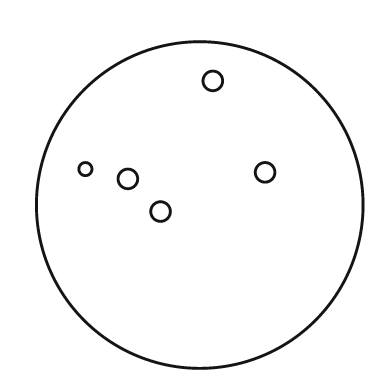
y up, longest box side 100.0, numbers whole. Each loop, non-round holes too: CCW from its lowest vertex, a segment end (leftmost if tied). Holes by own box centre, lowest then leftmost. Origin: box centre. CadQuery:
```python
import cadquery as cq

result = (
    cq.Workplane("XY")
    .moveTo(0.0, 0.0)
    .circle(50.0)
    .moveTo(-12.0, -2.0)
    .circle(3.0)
    .moveTo(-22.0, 8.0)
    .circle(3.0)
    .moveTo(20.0, 10.0)
    .circle(3.0)
    .moveTo(-35.0, 11.0)
    .circle(2.0)
    .moveTo(4.0, 38.0)
    .circle(3.0)
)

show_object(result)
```